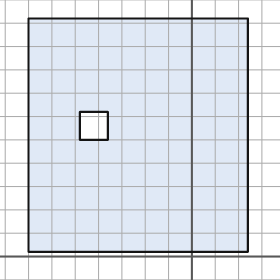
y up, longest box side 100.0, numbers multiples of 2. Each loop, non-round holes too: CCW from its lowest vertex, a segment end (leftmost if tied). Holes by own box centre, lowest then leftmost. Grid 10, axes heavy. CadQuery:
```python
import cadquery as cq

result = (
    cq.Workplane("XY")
    .moveTo(-70.0, 2.0)
    .lineTo(24.0, 2.0)
    .lineTo(24.0, 102.0)
    .lineTo(-70.0, 102.0)
    .close()
    .moveTo(-48.0, 50.0)
    .lineTo(-36.0, 50.0)
    .lineTo(-36.0, 62.0)
    .lineTo(-48.0, 62.0)
    .close()
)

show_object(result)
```